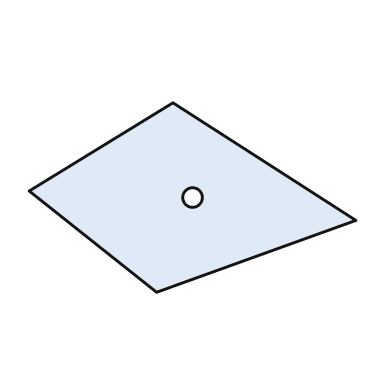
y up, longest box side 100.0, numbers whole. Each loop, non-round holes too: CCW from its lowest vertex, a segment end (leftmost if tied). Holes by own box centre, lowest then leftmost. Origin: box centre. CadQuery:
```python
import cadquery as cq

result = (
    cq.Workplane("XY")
    .moveTo(-11.0, -29.0)
    .lineTo(50.0, -7.0)
    .lineTo(-6.0, 29.0)
    .lineTo(-50.0, 2.0)
    .close()
    .moveTo(0.0, 0.0)
    .circle(3.0)
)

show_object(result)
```